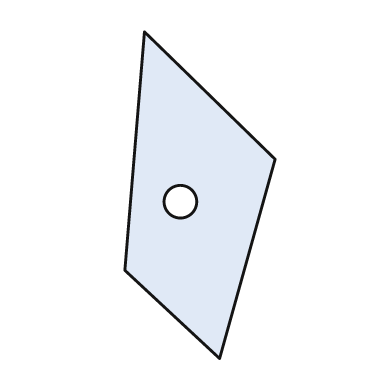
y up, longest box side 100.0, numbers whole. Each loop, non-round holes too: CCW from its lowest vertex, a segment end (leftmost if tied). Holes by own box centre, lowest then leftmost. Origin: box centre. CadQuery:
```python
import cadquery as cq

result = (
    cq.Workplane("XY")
    .moveTo(6.0, -50.0)
    .lineTo(23.0, 11.0)
    .lineTo(-17.0, 50.0)
    .lineTo(-23.0, -23.0)
    .close()
    .moveTo(-6.0, -2.0)
    .circle(5.0)
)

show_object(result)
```